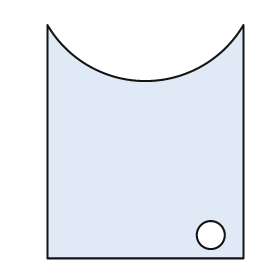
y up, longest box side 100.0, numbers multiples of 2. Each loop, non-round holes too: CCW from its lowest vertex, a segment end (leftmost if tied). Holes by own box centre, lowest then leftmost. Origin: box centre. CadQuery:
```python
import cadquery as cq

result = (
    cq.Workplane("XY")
    .moveTo(-42.0, -50.0)
    .lineTo(42.0, -50.0)
    .lineTo(42.0, 50.0)
    .threePointArc((0.0, 26.0), (-42.0, 50.0))
    .close()
    .moveTo(28.0, -40.0)
    .circle(6.0)
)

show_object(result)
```